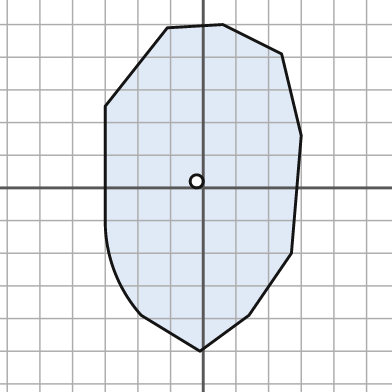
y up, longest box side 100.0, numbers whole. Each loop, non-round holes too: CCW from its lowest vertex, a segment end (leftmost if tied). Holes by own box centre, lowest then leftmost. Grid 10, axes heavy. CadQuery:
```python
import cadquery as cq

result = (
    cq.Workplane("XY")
    .moveTo(-1.0, -50.0)
    .lineTo(14.0, -39.0)
    .lineTo(27.0, -20.0)
    .lineTo(30.0, 16.0)
    .lineTo(24.0, 41.0)
    .lineTo(6.0, 50.0)
    .lineTo(-11.0, 49.0)
    .lineTo(-30.0, 25.0)
    .lineTo(-30.0, -11.0)
    .threePointArc((-27.0, -26.0), (-19.0, -39.0))
    .close()
    .moveTo(-2.0, 2.0)
    .circle(2.0)
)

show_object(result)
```